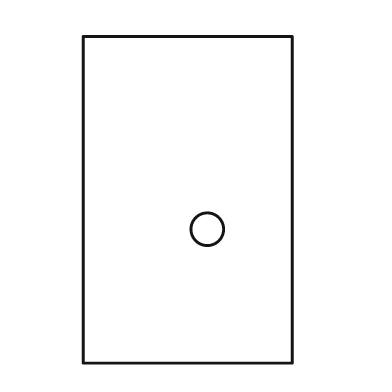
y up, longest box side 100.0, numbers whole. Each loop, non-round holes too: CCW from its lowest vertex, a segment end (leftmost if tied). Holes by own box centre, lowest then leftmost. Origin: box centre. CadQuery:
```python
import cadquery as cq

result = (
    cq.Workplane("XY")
    .moveTo(-32.0, -50.0)
    .lineTo(32.0, -50.0)
    .lineTo(32.0, 50.0)
    .lineTo(-32.0, 50.0)
    .close()
    .moveTo(6.0, -9.0)
    .circle(5.0)
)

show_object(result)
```